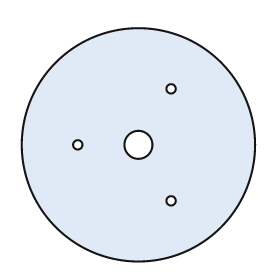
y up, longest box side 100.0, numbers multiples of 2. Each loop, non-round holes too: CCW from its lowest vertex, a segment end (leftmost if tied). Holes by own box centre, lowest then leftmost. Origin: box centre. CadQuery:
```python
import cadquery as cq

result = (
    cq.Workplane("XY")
    .moveTo(0.0, 0.0)
    .circle(50.0)
    .moveTo(14.0, -24.0)
    .circle(2.0)
    .moveTo(-26.0, 0.0)
    .circle(2.0)
    .moveTo(0.0, 0.0)
    .circle(6.0)
    .moveTo(14.0, 24.0)
    .circle(2.0)
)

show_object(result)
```